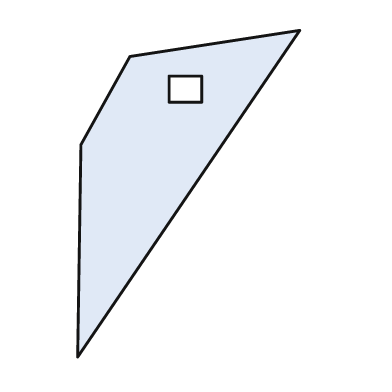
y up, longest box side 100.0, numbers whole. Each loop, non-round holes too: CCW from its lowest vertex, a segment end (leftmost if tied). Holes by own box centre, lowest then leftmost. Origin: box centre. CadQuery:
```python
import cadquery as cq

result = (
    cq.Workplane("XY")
    .moveTo(-34.0, -50.0)
    .lineTo(34.0, 50.0)
    .lineTo(-18.0, 42.0)
    .lineTo(-33.0, 15.0)
    .close()
    .moveTo(-6.0, 28.0)
    .lineTo(4.0, 28.0)
    .lineTo(4.0, 36.0)
    .lineTo(-6.0, 36.0)
    .close()
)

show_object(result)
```